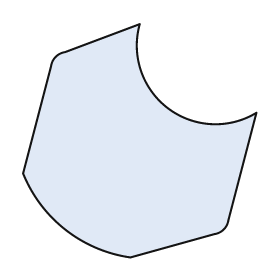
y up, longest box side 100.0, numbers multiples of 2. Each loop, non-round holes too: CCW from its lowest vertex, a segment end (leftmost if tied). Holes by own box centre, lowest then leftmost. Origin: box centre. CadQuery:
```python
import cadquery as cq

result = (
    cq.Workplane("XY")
    .moveTo(-4.0, -50.0)
    .lineTo(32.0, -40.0)
    .threePointArc((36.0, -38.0), (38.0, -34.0))
    .lineTo(50.0, 12.0)
    .threePointArc((12.0, 14.0), (0.0, 50.0))
    .lineTo(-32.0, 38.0)
    .threePointArc((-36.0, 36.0), (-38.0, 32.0))
    .lineTo(-50.0, -14.0)
    .threePointArc((-32.0, -38.0), (-4.0, -50.0))
    .close()
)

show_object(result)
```